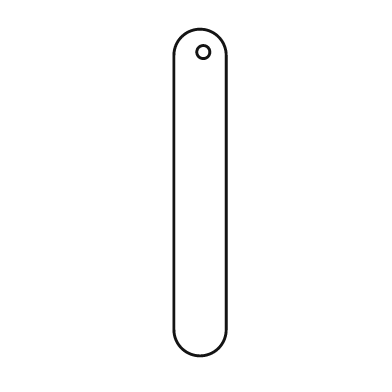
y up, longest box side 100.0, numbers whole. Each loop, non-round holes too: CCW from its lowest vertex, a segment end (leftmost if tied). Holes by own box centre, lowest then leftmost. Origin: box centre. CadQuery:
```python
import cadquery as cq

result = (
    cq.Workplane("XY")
    .moveTo(-8.0, -42.0)
    .threePointArc((0.0, -50.0), (8.0, -42.0))
    .lineTo(8.0, 42.0)
    .threePointArc((0.0, 50.0), (-8.0, 42.0))
    .close()
    .moveTo(1.0, 43.0)
    .circle(2.0)
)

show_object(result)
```